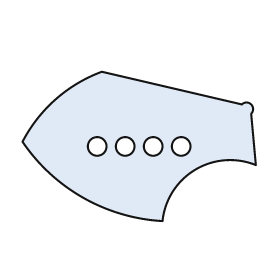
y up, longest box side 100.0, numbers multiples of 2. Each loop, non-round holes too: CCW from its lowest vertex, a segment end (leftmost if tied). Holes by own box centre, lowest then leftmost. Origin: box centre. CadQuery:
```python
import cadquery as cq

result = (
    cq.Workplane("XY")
    .moveTo(10.0, -32.0)
    .threePointArc((24.0, -10.0), (50.0, -8.0))
    .lineTo(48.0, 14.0)
    .threePointArc((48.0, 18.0), (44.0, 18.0))
    .lineTo(-16.0, 32.0)
    .threePointArc((-36.0, 20.0), (-50.0, 2.0))
    .threePointArc((-24.0, -22.0), (10.0, -32.0))
    .close()
    .moveTo(-18.0, 0.0)
    .circle(4.0)
    .moveTo(-6.0, 0.0)
    .circle(4.0)
    .moveTo(6.0, 0.0)
    .circle(4.0)
    .moveTo(18.0, 0.0)
    .circle(4.0)
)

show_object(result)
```